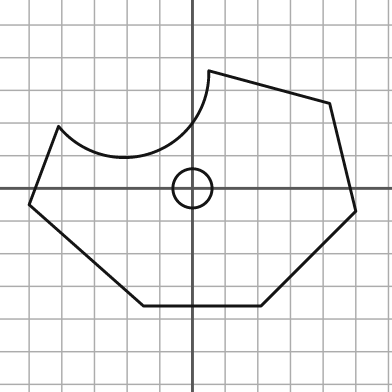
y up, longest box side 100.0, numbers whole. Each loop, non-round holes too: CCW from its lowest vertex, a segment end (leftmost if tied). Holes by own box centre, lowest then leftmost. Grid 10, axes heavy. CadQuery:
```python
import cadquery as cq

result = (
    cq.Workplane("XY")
    .moveTo(-15.0, -36.0)
    .lineTo(21.0, -36.0)
    .lineTo(50.0, -7.0)
    .lineTo(42.0, 26.0)
    .lineTo(5.0, 36.0)
    .threePointArc((-12.0, 11.0), (-41.0, 19.0))
    .lineTo(-50.0, -5.0)
    .close()
    .moveTo(0.0, 0.0)
    .circle(6.0)
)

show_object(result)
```